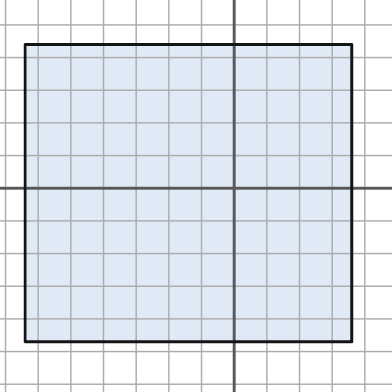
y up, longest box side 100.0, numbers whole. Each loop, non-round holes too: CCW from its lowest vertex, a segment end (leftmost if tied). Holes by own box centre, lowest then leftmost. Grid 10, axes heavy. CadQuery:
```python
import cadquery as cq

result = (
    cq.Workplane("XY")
    .moveTo(-64.0, -47.0)
    .lineTo(36.0, -47.0)
    .lineTo(36.0, 44.0)
    .lineTo(-64.0, 44.0)
    .close()
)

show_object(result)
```